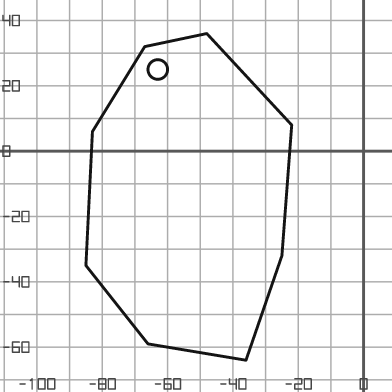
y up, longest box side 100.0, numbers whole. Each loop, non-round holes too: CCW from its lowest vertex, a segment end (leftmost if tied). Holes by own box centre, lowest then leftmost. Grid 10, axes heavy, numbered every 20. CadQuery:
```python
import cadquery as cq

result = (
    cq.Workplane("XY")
    .moveTo(-36.0, -64.0)
    .lineTo(-25.0, -32.0)
    .lineTo(-22.0, 8.0)
    .lineTo(-48.0, 36.0)
    .lineTo(-67.0, 32.0)
    .lineTo(-83.0, 6.0)
    .lineTo(-85.0, -35.0)
    .lineTo(-66.0, -59.0)
    .close()
    .moveTo(-63.0, 25.0)
    .circle(3.0)
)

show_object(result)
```